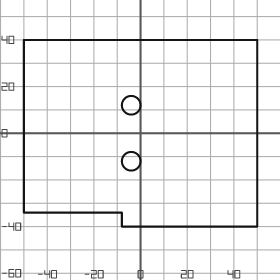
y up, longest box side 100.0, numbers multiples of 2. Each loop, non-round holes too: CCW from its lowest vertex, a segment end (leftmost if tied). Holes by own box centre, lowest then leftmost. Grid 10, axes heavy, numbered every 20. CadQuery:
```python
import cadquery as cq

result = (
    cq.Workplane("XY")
    .moveTo(-8.0, -40.0)
    .lineTo(50.0, -40.0)
    .lineTo(50.0, 40.0)
    .lineTo(-50.0, 40.0)
    .lineTo(-50.0, -34.0)
    .lineTo(-8.0, -34.0)
    .close()
    .moveTo(-4.0, -12.0)
    .circle(4.0)
    .moveTo(-4.0, 12.0)
    .circle(4.0)
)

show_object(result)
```